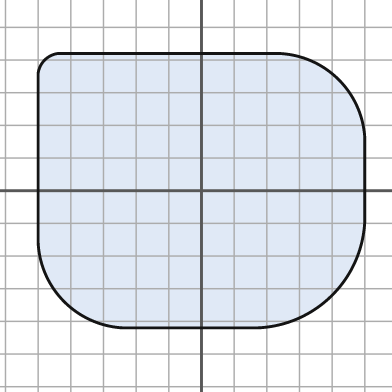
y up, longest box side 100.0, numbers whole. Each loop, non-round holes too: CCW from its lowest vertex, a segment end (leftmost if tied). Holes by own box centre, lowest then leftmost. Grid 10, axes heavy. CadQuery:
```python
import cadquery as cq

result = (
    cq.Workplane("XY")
    .moveTo(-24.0, -42.0)
    .lineTo(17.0, -42.0)
    .threePointArc((40.0, -32.0), (50.0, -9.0))
    .lineTo(50.0, 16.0)
    .threePointArc((42.0, 34.0), (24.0, 42.0))
    .lineTo(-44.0, 42.0)
    .threePointArc((-48.0, 40.0), (-50.0, 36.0))
    .lineTo(-50.0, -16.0)
    .threePointArc((-42.0, -34.0), (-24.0, -42.0))
    .close()
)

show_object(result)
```